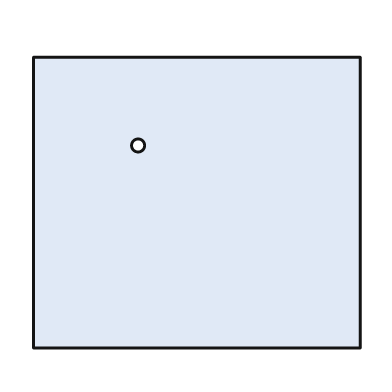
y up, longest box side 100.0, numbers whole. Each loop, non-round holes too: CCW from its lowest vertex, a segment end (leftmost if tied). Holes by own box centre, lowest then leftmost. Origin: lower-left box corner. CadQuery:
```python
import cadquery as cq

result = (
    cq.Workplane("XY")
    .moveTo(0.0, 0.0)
    .lineTo(100.0, 0.0)
    .lineTo(100.0, 89.0)
    .lineTo(0.0, 89.0)
    .close()
    .moveTo(32.0, 62.0)
    .circle(2.0)
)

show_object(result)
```